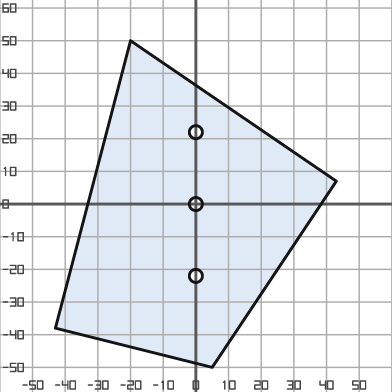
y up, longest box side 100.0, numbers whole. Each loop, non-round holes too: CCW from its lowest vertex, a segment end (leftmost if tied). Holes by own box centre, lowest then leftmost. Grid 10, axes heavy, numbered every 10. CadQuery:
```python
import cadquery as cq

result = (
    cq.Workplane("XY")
    .moveTo(5.0, -50.0)
    .lineTo(43.0, 7.0)
    .lineTo(-20.0, 50.0)
    .lineTo(-43.0, -38.0)
    .close()
    .moveTo(0.0, -22.0)
    .circle(2.0)
    .moveTo(0.0, 0.0)
    .circle(2.0)
    .moveTo(0.0, 22.0)
    .circle(2.0)
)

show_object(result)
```